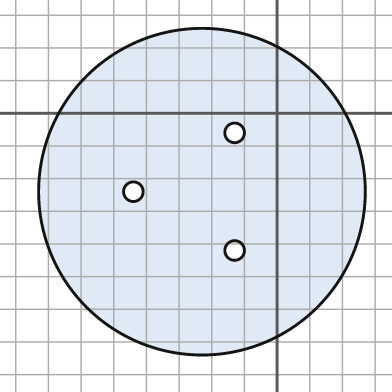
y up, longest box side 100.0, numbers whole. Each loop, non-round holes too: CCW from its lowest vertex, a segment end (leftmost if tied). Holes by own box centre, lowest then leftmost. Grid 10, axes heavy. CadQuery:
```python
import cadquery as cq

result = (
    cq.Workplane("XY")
    .moveTo(-23.0, -24.0)
    .circle(50.0)
    .moveTo(-13.0, -42.0)
    .circle(3.0)
    .moveTo(-44.0, -24.0)
    .circle(3.0)
    .moveTo(-13.0, -6.0)
    .circle(3.0)
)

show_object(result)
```